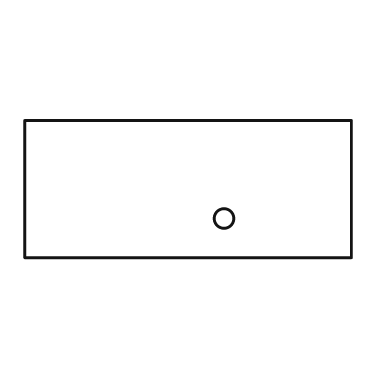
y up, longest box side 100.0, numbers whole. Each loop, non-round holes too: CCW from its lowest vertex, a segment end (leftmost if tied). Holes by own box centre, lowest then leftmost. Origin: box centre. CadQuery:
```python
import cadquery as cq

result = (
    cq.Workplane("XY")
    .moveTo(-50.0, -21.0)
    .lineTo(50.0, -21.0)
    .lineTo(50.0, 21.0)
    .lineTo(-50.0, 21.0)
    .close()
    .moveTo(11.0, -9.0)
    .circle(3.0)
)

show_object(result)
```